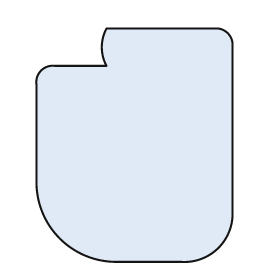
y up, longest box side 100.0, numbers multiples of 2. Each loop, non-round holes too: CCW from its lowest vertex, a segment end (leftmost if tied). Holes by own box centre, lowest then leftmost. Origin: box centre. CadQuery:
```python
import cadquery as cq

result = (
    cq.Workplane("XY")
    .moveTo(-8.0, -50.0)
    .lineTo(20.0, -50.0)
    .threePointArc((36.0, -44.0), (42.0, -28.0))
    .lineTo(42.0, 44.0)
    .threePointArc((40.0, 48.0), (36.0, 50.0))
    .lineTo(-12.0, 50.0)
    .threePointArc((-14.0, 42.0), (-12.0, 34.0))
    .lineTo(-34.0, 34.0)
    .threePointArc((-40.0, 32.0), (-42.0, 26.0))
    .lineTo(-42.0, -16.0)
    .threePointArc((-32.0, -40.0), (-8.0, -50.0))
    .close()
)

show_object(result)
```